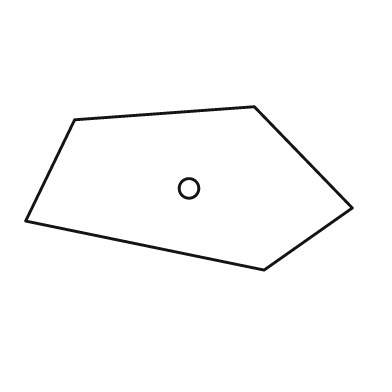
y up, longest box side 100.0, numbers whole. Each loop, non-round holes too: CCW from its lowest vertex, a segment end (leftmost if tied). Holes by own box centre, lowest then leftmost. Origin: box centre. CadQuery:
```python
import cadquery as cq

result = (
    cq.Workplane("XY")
    .moveTo(23.0, -25.0)
    .lineTo(50.0, -6.0)
    .lineTo(20.0, 25.0)
    .lineTo(-35.0, 21.0)
    .lineTo(-50.0, -10.0)
    .close()
    .moveTo(0.0, 0.0)
    .circle(3.0)
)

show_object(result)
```